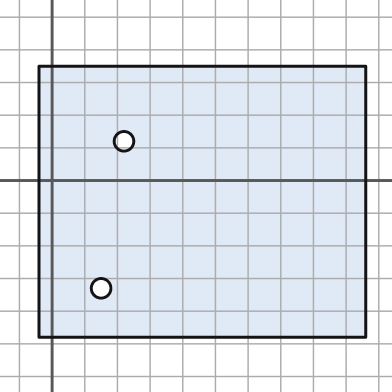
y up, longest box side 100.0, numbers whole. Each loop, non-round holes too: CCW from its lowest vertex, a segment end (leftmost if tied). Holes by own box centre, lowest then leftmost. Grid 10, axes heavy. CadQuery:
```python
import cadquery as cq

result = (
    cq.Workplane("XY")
    .moveTo(-4.0, -48.0)
    .lineTo(96.0, -48.0)
    .lineTo(96.0, 35.0)
    .lineTo(-4.0, 35.0)
    .close()
    .moveTo(15.0, -33.0)
    .circle(3.0)
    .moveTo(22.0, 12.0)
    .circle(3.0)
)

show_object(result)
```